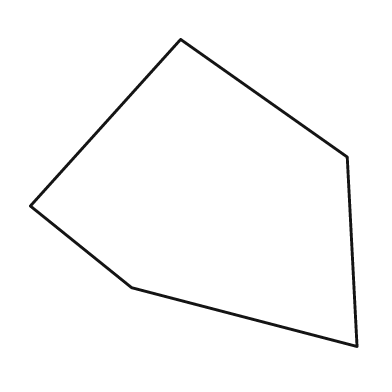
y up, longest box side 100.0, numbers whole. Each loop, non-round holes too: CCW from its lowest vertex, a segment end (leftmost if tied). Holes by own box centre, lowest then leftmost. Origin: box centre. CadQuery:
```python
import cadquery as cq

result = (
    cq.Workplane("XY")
    .moveTo(50.0, -47.0)
    .lineTo(47.0, 11.0)
    .lineTo(-4.0, 47.0)
    .lineTo(-50.0, -4.0)
    .lineTo(-19.0, -29.0)
    .close()
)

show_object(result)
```